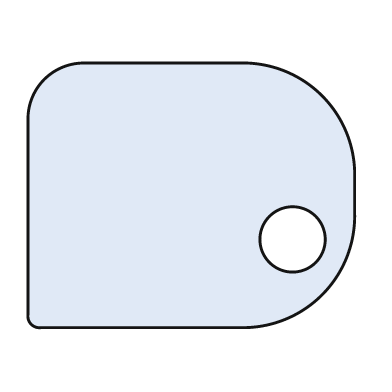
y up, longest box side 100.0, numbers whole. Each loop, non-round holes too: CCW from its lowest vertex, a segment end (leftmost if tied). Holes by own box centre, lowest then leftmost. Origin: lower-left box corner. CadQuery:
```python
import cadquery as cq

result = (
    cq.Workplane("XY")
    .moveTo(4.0, 0.0)
    .lineTo(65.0, 0.0)
    .threePointArc((90.0, 10.0), (100.0, 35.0))
    .lineTo(100.0, 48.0)
    .threePointArc((90.0, 71.0), (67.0, 81.0))
    .lineTo(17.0, 81.0)
    .threePointArc((5.0, 76.0), (0.0, 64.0))
    .lineTo(0.0, 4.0)
    .threePointArc((1.0, 1.0), (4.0, 0.0))
    .close()
    .moveTo(81.0, 27.0)
    .circle(10.0)
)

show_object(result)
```